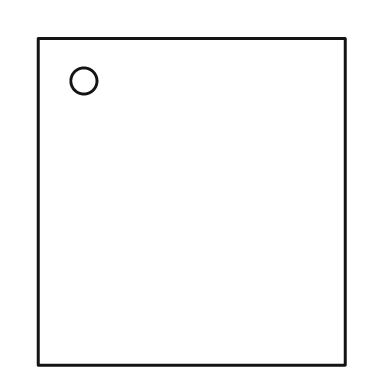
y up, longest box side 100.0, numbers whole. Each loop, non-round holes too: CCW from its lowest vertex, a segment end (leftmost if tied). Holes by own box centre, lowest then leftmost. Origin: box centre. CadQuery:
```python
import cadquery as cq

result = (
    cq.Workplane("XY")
    .moveTo(-47.0, -50.0)
    .lineTo(47.0, -50.0)
    .lineTo(47.0, 50.0)
    .lineTo(-47.0, 50.0)
    .close()
    .moveTo(-33.0, 37.0)
    .circle(4.0)
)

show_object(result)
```